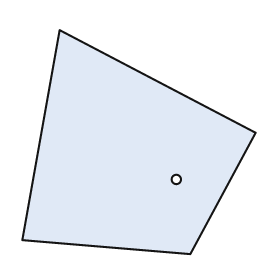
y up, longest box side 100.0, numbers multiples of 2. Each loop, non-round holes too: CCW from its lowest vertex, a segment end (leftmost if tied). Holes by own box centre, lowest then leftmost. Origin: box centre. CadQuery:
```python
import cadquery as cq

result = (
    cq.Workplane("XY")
    .moveTo(22.0, -48.0)
    .lineTo(50.0, 4.0)
    .lineTo(-34.0, 48.0)
    .lineTo(-50.0, -42.0)
    .close()
    .moveTo(16.0, -16.0)
    .circle(2.0)
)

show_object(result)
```